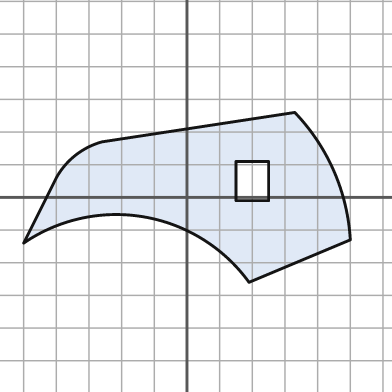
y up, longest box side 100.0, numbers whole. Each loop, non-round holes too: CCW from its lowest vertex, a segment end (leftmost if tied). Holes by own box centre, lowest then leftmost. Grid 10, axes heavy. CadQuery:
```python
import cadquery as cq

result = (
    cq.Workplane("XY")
    .moveTo(19.0, -26.0)
    .lineTo(50.0, -13.0)
    .threePointArc((45.0, 8.0), (33.0, 26.0))
    .lineTo(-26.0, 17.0)
    .threePointArc((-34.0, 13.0), (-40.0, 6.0))
    .lineTo(-50.0, -14.0)
    .threePointArc((-13.0, -6.0), (19.0, -26.0))
    .close()
    .moveTo(15.0, -1.0)
    .lineTo(25.0, -1.0)
    .lineTo(25.0, 11.0)
    .lineTo(15.0, 11.0)
    .close()
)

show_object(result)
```